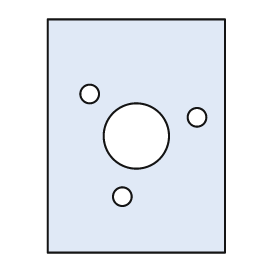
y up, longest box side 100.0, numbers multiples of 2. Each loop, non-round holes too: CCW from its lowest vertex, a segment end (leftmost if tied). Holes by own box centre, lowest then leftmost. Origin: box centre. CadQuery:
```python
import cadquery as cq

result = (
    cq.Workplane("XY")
    .moveTo(-38.0, -50.0)
    .lineTo(38.0, -50.0)
    .lineTo(38.0, 50.0)
    .lineTo(-38.0, 50.0)
    .close()
    .moveTo(-6.0, -26.0)
    .circle(4.0)
    .moveTo(0.0, 0.0)
    .circle(14.0)
    .moveTo(26.0, 8.0)
    .circle(4.0)
    .moveTo(-20.0, 18.0)
    .circle(4.0)
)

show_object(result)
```